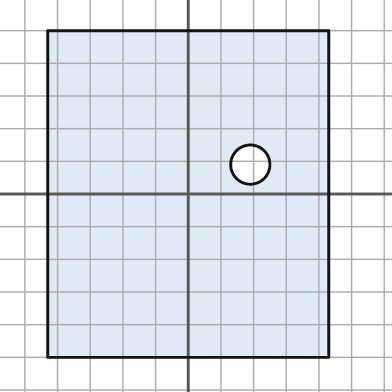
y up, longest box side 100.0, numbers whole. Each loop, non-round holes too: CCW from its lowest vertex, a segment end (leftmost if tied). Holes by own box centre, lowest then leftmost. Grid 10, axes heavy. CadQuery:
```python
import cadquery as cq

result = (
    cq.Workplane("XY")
    .moveTo(-43.0, -50.0)
    .lineTo(43.0, -50.0)
    .lineTo(43.0, 50.0)
    .lineTo(-43.0, 50.0)
    .close()
    .moveTo(19.0, 9.0)
    .circle(6.0)
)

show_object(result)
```